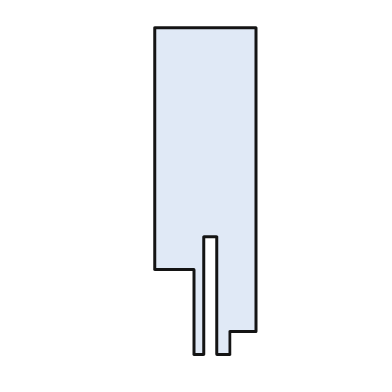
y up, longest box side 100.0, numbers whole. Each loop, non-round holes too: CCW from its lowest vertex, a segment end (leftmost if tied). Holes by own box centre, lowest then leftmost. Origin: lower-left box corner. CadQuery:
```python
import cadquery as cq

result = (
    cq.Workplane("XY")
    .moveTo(12.0, 0.0)
    .lineTo(15.0, 0.0)
    .lineTo(15.0, 36.0)
    .lineTo(19.0, 36.0)
    .lineTo(19.0, 0.0)
    .lineTo(23.0, 0.0)
    .lineTo(23.0, 7.0)
    .lineTo(31.0, 7.0)
    .lineTo(31.0, 100.0)
    .lineTo(0.0, 100.0)
    .lineTo(0.0, 26.0)
    .lineTo(12.0, 26.0)
    .close()
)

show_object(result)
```